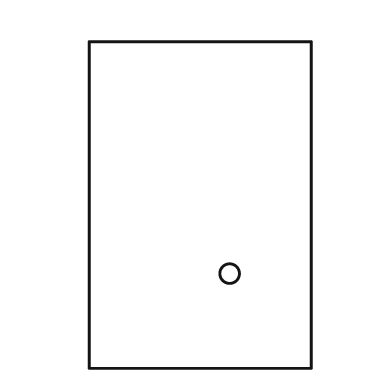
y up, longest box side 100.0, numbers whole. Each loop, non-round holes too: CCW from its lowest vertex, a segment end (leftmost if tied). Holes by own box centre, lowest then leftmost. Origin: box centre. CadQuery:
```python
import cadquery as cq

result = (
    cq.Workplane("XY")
    .moveTo(-34.0, -50.0)
    .lineTo(34.0, -50.0)
    .lineTo(34.0, 50.0)
    .lineTo(-34.0, 50.0)
    .close()
    .moveTo(9.0, -21.0)
    .circle(3.0)
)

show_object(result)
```